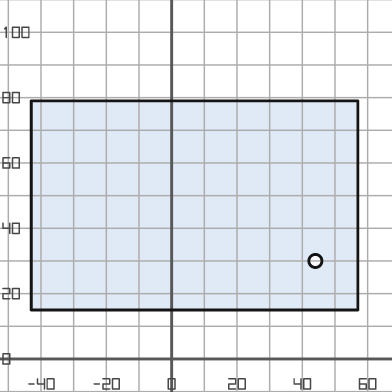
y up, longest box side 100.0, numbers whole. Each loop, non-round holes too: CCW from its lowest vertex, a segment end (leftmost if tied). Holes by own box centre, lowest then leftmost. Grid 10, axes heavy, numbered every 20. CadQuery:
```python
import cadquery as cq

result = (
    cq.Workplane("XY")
    .moveTo(-43.0, 15.0)
    .lineTo(57.0, 15.0)
    .lineTo(57.0, 79.0)
    .lineTo(-43.0, 79.0)
    .close()
    .moveTo(44.0, 30.0)
    .circle(2.0)
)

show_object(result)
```